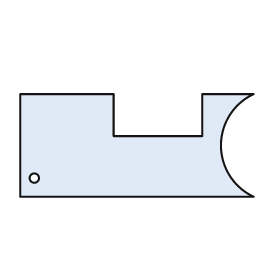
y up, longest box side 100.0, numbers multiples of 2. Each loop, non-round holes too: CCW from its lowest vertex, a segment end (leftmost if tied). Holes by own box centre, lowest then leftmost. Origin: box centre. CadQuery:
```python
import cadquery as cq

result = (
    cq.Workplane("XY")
    .moveTo(-50.0, -22.0)
    .lineTo(50.0, -22.0)
    .threePointArc((36.0, 0.0), (50.0, 22.0))
    .lineTo(28.0, 22.0)
    .lineTo(28.0, 4.0)
    .lineTo(-10.0, 4.0)
    .lineTo(-10.0, 22.0)
    .lineTo(-50.0, 22.0)
    .close()
    .moveTo(-44.0, -14.0)
    .circle(2.0)
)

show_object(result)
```